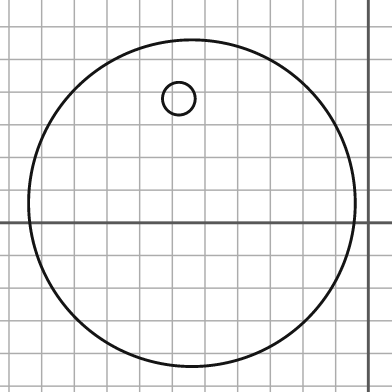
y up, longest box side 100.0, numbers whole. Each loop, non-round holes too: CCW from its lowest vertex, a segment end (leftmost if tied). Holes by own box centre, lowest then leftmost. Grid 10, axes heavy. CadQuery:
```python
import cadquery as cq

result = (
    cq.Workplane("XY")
    .moveTo(-54.0, 6.0)
    .circle(50.0)
    .moveTo(-58.0, 38.0)
    .circle(5.0)
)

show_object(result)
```